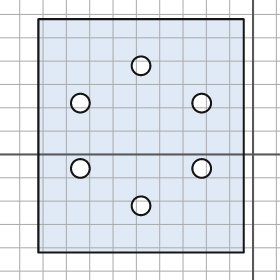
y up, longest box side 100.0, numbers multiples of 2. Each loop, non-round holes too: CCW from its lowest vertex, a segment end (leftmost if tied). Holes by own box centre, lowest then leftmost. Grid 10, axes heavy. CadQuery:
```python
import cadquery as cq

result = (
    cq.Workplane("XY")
    .moveTo(-92.0, -42.0)
    .lineTo(-4.0, -42.0)
    .lineTo(-4.0, 58.0)
    .lineTo(-92.0, 58.0)
    .close()
    .moveTo(-48.0, -22.0)
    .circle(4.0)
    .moveTo(-74.0, -6.0)
    .circle(4.0)
    .moveTo(-22.0, -6.0)
    .circle(4.0)
    .moveTo(-74.0, 22.0)
    .circle(4.0)
    .moveTo(-22.0, 22.0)
    .circle(4.0)
    .moveTo(-48.0, 38.0)
    .circle(4.0)
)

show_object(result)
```